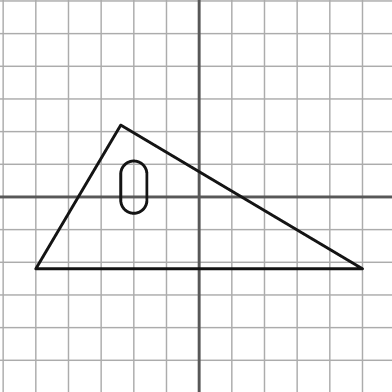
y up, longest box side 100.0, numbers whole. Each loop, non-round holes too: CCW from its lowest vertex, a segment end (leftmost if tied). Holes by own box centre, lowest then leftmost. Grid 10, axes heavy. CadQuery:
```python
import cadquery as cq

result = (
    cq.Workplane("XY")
    .moveTo(-50.0, -22.0)
    .lineTo(50.0, -22.0)
    .lineTo(-24.0, 22.0)
    .close()
    .moveTo(-24.0, -1.0)
    .threePointArc((-20.0, -5.0), (-16.0, -1.0))
    .lineTo(-16.0, 7.0)
    .threePointArc((-20.0, 11.0), (-24.0, 7.0))
    .close()
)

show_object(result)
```